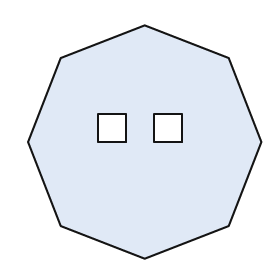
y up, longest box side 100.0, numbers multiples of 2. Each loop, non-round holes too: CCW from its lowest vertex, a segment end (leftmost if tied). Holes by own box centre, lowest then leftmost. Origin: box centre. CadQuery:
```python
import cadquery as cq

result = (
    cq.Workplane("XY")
    .moveTo(0.0, -50.0)
    .lineTo(36.0, -36.0)
    .lineTo(50.0, 0.0)
    .lineTo(36.0, 36.0)
    .lineTo(0.0, 50.0)
    .lineTo(-36.0, 36.0)
    .lineTo(-50.0, 0.0)
    .lineTo(-36.0, -36.0)
    .close()
    .moveTo(-20.0, 0.0)
    .lineTo(-8.0, 0.0)
    .lineTo(-8.0, 12.0)
    .lineTo(-20.0, 12.0)
    .close()
    .moveTo(4.0, 0.0)
    .lineTo(16.0, 0.0)
    .lineTo(16.0, 12.0)
    .lineTo(4.0, 12.0)
    .close()
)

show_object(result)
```